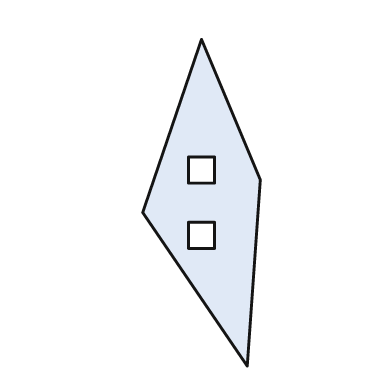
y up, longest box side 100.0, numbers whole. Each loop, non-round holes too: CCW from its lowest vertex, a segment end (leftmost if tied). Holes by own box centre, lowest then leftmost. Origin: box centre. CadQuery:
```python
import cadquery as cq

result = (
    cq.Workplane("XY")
    .moveTo(14.0, -50.0)
    .lineTo(18.0, 7.0)
    .lineTo(0.0, 50.0)
    .lineTo(-18.0, -3.0)
    .close()
    .moveTo(-4.0, -14.0)
    .lineTo(4.0, -14.0)
    .lineTo(4.0, -6.0)
    .lineTo(-4.0, -6.0)
    .close()
    .moveTo(-4.0, 6.0)
    .lineTo(4.0, 6.0)
    .lineTo(4.0, 14.0)
    .lineTo(-4.0, 14.0)
    .close()
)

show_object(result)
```